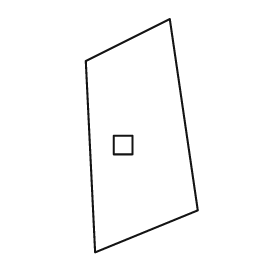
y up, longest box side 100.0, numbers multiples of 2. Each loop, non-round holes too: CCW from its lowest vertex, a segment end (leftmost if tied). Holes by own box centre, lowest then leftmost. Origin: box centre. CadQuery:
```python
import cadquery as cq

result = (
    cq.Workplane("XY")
    .moveTo(-20.0, -50.0)
    .lineTo(24.0, -32.0)
    .lineTo(12.0, 50.0)
    .lineTo(-24.0, 32.0)
    .close()
    .moveTo(-12.0, -8.0)
    .lineTo(-4.0, -8.0)
    .lineTo(-4.0, 0.0)
    .lineTo(-12.0, 0.0)
    .close()
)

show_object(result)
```